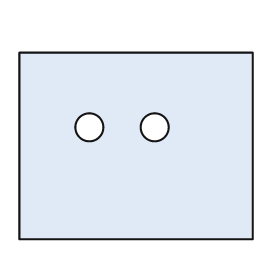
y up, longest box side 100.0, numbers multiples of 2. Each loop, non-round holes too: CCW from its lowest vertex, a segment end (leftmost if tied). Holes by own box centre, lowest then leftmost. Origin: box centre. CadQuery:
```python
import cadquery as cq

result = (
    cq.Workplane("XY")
    .moveTo(-50.0, -40.0)
    .lineTo(50.0, -40.0)
    .lineTo(50.0, 40.0)
    .lineTo(-50.0, 40.0)
    .close()
    .moveTo(-20.0, 8.0)
    .circle(6.0)
    .moveTo(8.0, 8.0)
    .circle(6.0)
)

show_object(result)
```